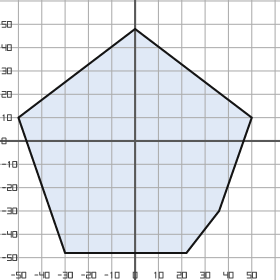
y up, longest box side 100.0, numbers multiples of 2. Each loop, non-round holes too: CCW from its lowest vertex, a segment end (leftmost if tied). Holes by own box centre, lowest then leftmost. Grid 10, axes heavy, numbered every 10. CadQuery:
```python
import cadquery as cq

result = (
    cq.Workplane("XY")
    .moveTo(-30.0, -48.0)
    .lineTo(22.0, -48.0)
    .lineTo(36.0, -30.0)
    .lineTo(50.0, 10.0)
    .lineTo(0.0, 48.0)
    .lineTo(-50.0, 10.0)
    .close()
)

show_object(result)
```